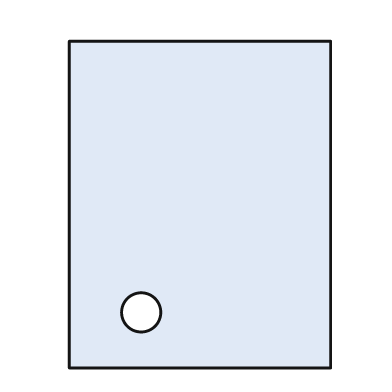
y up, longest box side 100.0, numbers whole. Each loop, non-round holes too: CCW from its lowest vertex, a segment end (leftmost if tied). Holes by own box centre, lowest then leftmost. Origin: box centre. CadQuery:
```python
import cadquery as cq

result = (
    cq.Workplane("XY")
    .moveTo(-40.0, -50.0)
    .lineTo(40.0, -50.0)
    .lineTo(40.0, 50.0)
    .lineTo(-40.0, 50.0)
    .close()
    .moveTo(-18.0, -33.0)
    .circle(6.0)
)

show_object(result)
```